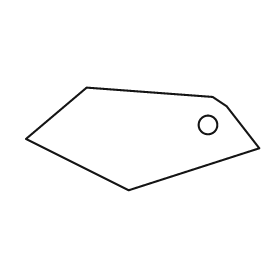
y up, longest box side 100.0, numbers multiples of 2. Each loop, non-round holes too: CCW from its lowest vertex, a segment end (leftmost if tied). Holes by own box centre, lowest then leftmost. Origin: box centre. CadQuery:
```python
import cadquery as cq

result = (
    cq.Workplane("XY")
    .moveTo(-6.0, -22.0)
    .lineTo(50.0, -4.0)
    .lineTo(36.0, 14.0)
    .lineTo(30.0, 18.0)
    .lineTo(-24.0, 22.0)
    .lineTo(-50.0, 0.0)
    .close()
    .moveTo(28.0, 6.0)
    .circle(4.0)
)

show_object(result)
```